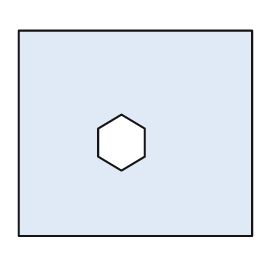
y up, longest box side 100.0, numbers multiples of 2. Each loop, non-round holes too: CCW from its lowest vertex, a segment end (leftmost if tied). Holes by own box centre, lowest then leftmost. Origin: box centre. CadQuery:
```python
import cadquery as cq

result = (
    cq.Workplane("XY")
    .moveTo(-50.0, -44.0)
    .lineTo(50.0, -44.0)
    .lineTo(50.0, 44.0)
    .lineTo(-50.0, 44.0)
    .close()
    .moveTo(-6.0, -16.0)
    .lineTo(4.0, -10.0)
    .lineTo(4.0, 2.0)
    .lineTo(-6.0, 8.0)
    .lineTo(-16.0, 2.0)
    .lineTo(-16.0, -10.0)
    .close()
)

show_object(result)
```